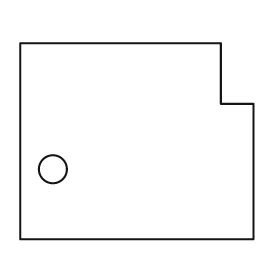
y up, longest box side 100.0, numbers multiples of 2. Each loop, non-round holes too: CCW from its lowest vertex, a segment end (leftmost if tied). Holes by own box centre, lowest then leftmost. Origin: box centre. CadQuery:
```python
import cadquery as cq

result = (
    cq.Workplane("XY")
    .moveTo(-50.0, -42.0)
    .lineTo(50.0, -42.0)
    .lineTo(50.0, 16.0)
    .lineTo(36.0, 16.0)
    .lineTo(36.0, 42.0)
    .lineTo(-50.0, 42.0)
    .close()
    .moveTo(-36.0, -12.0)
    .circle(6.0)
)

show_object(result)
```